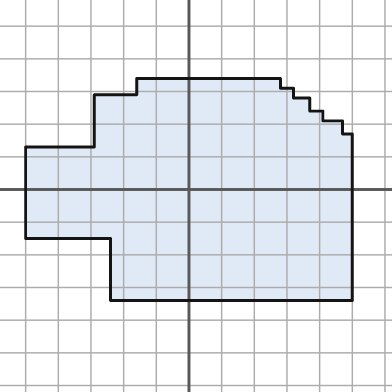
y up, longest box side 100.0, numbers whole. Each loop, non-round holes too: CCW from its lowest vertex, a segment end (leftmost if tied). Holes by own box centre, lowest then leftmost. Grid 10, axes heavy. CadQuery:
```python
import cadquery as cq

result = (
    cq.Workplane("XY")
    .moveTo(-24.0, -34.0)
    .lineTo(50.0, -34.0)
    .lineTo(50.0, 17.0)
    .lineTo(47.0, 17.0)
    .lineTo(47.0, 21.0)
    .lineTo(41.0, 21.0)
    .lineTo(41.0, 24.0)
    .lineTo(37.0, 24.0)
    .lineTo(37.0, 28.0)
    .lineTo(32.0, 28.0)
    .lineTo(32.0, 31.0)
    .lineTo(28.0, 31.0)
    .lineTo(28.0, 34.0)
    .lineTo(-16.0, 34.0)
    .lineTo(-16.0, 29.0)
    .lineTo(-29.0, 29.0)
    .lineTo(-29.0, 13.0)
    .lineTo(-50.0, 13.0)
    .lineTo(-50.0, -15.0)
    .lineTo(-24.0, -15.0)
    .close()
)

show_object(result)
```